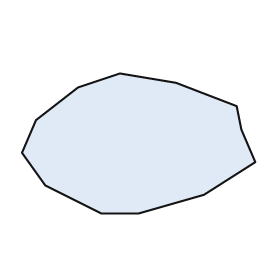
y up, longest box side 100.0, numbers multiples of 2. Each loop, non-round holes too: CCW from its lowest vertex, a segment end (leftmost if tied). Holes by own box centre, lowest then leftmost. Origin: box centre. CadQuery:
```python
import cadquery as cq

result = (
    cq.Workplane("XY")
    .moveTo(-16.0, -30.0)
    .lineTo(0.0, -30.0)
    .lineTo(28.0, -22.0)
    .lineTo(50.0, -8.0)
    .lineTo(44.0, 6.0)
    .lineTo(42.0, 16.0)
    .lineTo(16.0, 26.0)
    .lineTo(-8.0, 30.0)
    .lineTo(-26.0, 24.0)
    .lineTo(-44.0, 10.0)
    .lineTo(-50.0, -4.0)
    .lineTo(-40.0, -18.0)
    .close()
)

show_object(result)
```